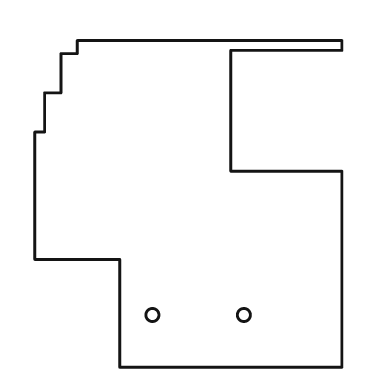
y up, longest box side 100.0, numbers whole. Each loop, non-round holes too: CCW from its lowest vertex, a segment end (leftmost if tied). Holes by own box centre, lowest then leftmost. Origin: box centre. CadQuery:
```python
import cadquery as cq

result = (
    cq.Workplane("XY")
    .moveTo(-21.0, -50.0)
    .lineTo(47.0, -50.0)
    .lineTo(47.0, 10.0)
    .lineTo(13.0, 10.0)
    .lineTo(13.0, 47.0)
    .lineTo(47.0, 47.0)
    .lineTo(47.0, 50.0)
    .lineTo(-34.0, 50.0)
    .lineTo(-34.0, 46.0)
    .lineTo(-39.0, 46.0)
    .lineTo(-39.0, 34.0)
    .lineTo(-44.0, 34.0)
    .lineTo(-44.0, 22.0)
    .lineTo(-47.0, 22.0)
    .lineTo(-47.0, -17.0)
    .lineTo(-21.0, -17.0)
    .close()
    .moveTo(-11.0, -34.0)
    .circle(2.0)
    .moveTo(17.0, -34.0)
    .circle(2.0)
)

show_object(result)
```